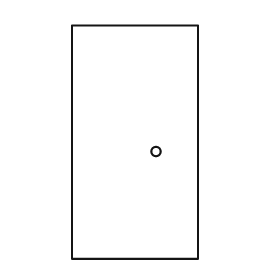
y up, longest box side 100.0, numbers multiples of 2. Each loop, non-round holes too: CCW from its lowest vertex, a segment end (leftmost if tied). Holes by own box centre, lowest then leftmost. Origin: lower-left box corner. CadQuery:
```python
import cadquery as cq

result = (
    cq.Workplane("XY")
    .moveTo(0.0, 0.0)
    .lineTo(54.0, 0.0)
    .lineTo(54.0, 100.0)
    .lineTo(0.0, 100.0)
    .close()
    .moveTo(36.0, 46.0)
    .circle(2.0)
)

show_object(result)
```